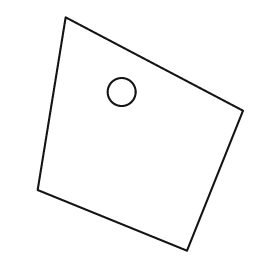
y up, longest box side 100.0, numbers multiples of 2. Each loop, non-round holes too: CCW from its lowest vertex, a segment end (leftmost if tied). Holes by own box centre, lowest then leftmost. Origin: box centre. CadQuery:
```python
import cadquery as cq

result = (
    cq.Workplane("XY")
    .moveTo(20.0, -50.0)
    .lineTo(44.0, 10.0)
    .lineTo(-32.0, 50.0)
    .lineTo(-44.0, -24.0)
    .close()
    .moveTo(-8.0, 18.0)
    .circle(6.0)
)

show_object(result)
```